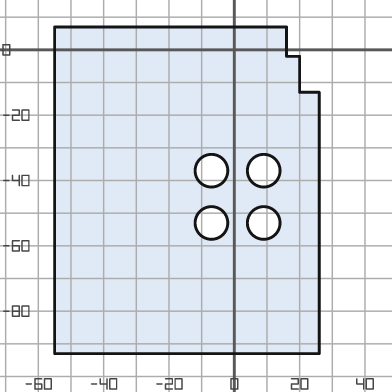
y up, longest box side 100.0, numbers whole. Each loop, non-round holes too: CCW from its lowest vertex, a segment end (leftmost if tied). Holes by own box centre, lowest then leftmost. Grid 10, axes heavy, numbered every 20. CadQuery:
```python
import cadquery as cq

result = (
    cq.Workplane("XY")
    .moveTo(-55.0, -93.0)
    .lineTo(26.0, -93.0)
    .lineTo(26.0, -13.0)
    .lineTo(20.0, -13.0)
    .lineTo(20.0, -2.0)
    .lineTo(16.0, -2.0)
    .lineTo(16.0, 7.0)
    .lineTo(-55.0, 7.0)
    .close()
    .moveTo(-7.0, -53.0)
    .circle(5.0)
    .moveTo(9.0, -53.0)
    .circle(5.0)
    .moveTo(-7.0, -37.0)
    .circle(5.0)
    .moveTo(9.0, -37.0)
    .circle(5.0)
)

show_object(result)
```